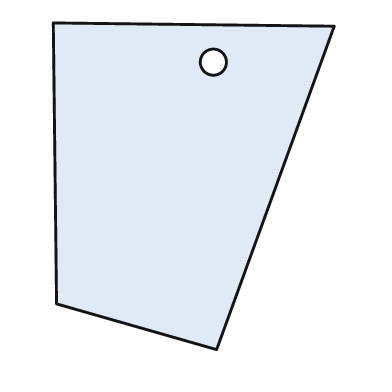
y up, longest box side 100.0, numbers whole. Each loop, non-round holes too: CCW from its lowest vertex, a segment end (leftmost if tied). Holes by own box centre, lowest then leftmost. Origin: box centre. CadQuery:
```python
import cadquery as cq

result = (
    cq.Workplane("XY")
    .moveTo(7.0, -50.0)
    .lineTo(43.0, 49.0)
    .lineTo(-43.0, 50.0)
    .lineTo(-42.0, -36.0)
    .close()
    .moveTo(6.0, 38.0)
    .circle(4.0)
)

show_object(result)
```